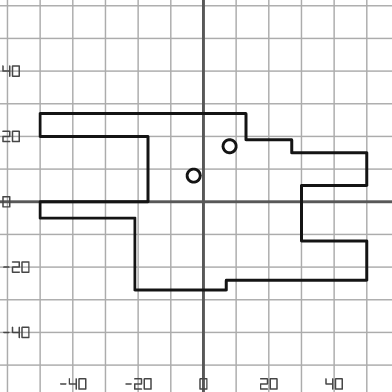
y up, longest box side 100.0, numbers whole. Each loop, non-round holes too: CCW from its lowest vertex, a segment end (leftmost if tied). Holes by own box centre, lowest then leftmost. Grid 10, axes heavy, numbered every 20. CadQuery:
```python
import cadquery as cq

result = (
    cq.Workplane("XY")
    .moveTo(-21.0, -27.0)
    .lineTo(7.0, -27.0)
    .lineTo(7.0, -24.0)
    .lineTo(50.0, -24.0)
    .lineTo(50.0, -12.0)
    .lineTo(30.0, -12.0)
    .lineTo(30.0, 5.0)
    .lineTo(50.0, 5.0)
    .lineTo(50.0, 15.0)
    .lineTo(27.0, 15.0)
    .lineTo(27.0, 19.0)
    .lineTo(13.0, 19.0)
    .lineTo(13.0, 27.0)
    .lineTo(-50.0, 27.0)
    .lineTo(-50.0, 20.0)
    .lineTo(-17.0, 20.0)
    .lineTo(-17.0, 0.0)
    .lineTo(-50.0, 0.0)
    .lineTo(-50.0, -5.0)
    .lineTo(-21.0, -5.0)
    .close()
    .moveTo(-3.0, 8.0)
    .circle(2.0)
    .moveTo(8.0, 17.0)
    .circle(2.0)
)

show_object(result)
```